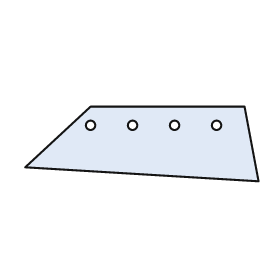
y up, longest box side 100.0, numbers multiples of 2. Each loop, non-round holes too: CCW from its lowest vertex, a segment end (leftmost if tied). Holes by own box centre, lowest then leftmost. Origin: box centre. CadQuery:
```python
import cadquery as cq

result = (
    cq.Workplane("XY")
    .moveTo(50.0, -16.0)
    .lineTo(44.0, 16.0)
    .lineTo(-22.0, 16.0)
    .lineTo(-50.0, -10.0)
    .close()
    .moveTo(-22.0, 8.0)
    .circle(2.0)
    .moveTo(-4.0, 8.0)
    .circle(2.0)
    .moveTo(14.0, 8.0)
    .circle(2.0)
    .moveTo(32.0, 8.0)
    .circle(2.0)
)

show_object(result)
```